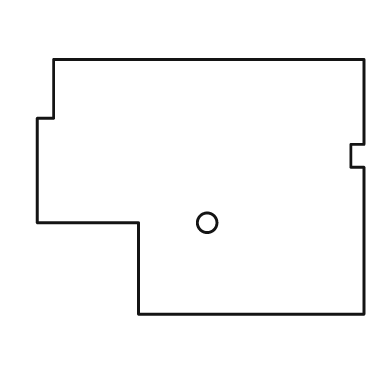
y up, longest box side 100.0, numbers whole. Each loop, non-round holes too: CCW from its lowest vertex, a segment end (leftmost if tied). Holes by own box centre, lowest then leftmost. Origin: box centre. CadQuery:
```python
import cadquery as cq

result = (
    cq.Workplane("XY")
    .moveTo(-19.0, -39.0)
    .lineTo(50.0, -39.0)
    .lineTo(50.0, 6.0)
    .lineTo(46.0, 6.0)
    .lineTo(46.0, 13.0)
    .lineTo(50.0, 13.0)
    .lineTo(50.0, 39.0)
    .lineTo(-45.0, 39.0)
    .lineTo(-45.0, 21.0)
    .lineTo(-50.0, 21.0)
    .lineTo(-50.0, -11.0)
    .lineTo(-19.0, -11.0)
    .close()
    .moveTo(2.0, -11.0)
    .circle(3.0)
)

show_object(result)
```